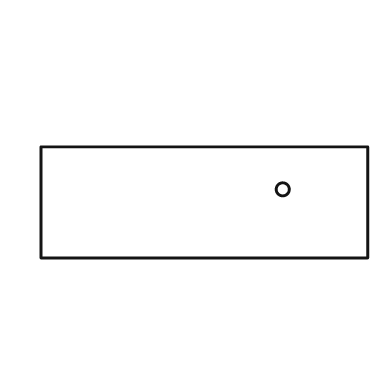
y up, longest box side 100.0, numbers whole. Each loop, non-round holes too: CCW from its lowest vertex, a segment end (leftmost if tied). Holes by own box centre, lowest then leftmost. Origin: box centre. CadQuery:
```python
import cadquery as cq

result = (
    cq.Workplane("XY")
    .moveTo(-50.0, -17.0)
    .lineTo(50.0, -17.0)
    .lineTo(50.0, 17.0)
    .lineTo(-50.0, 17.0)
    .close()
    .moveTo(24.0, 4.0)
    .circle(2.0)
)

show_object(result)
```